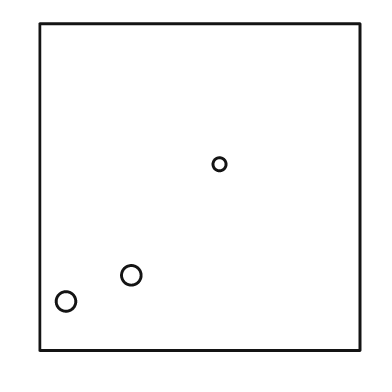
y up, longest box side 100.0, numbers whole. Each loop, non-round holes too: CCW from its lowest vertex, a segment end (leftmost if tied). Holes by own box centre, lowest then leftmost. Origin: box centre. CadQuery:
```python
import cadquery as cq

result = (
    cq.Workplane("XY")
    .moveTo(-49.0, -50.0)
    .lineTo(49.0, -50.0)
    .lineTo(49.0, 50.0)
    .lineTo(-49.0, 50.0)
    .close()
    .moveTo(-41.0, -35.0)
    .circle(3.0)
    .moveTo(-21.0, -27.0)
    .circle(3.0)
    .moveTo(6.0, 7.0)
    .circle(2.0)
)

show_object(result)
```